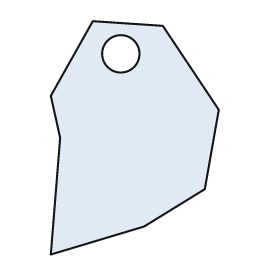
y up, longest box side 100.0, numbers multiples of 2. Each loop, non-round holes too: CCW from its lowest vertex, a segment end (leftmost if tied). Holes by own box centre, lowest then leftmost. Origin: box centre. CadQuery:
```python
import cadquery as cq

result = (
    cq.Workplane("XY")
    .moveTo(-36.0, -50.0)
    .lineTo(4.0, -38.0)
    .lineTo(30.0, -22.0)
    .lineTo(36.0, 12.0)
    .lineTo(12.0, 48.0)
    .lineTo(-18.0, 50.0)
    .lineTo(-36.0, 18.0)
    .lineTo(-32.0, 0.0)
    .close()
    .moveTo(-6.0, 36.0)
    .circle(8.0)
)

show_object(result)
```